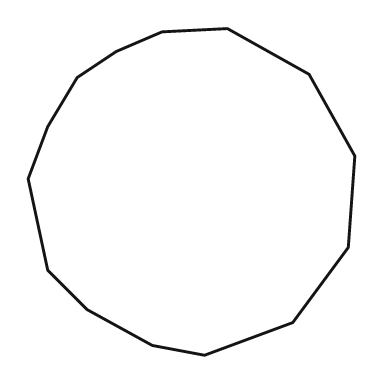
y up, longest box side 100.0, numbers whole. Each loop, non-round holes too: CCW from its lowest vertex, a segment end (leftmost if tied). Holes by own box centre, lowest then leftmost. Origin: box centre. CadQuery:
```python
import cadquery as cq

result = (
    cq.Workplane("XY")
    .moveTo(4.0, -50.0)
    .lineTo(31.0, -40.0)
    .lineTo(48.0, -17.0)
    .lineTo(50.0, 11.0)
    .lineTo(36.0, 36.0)
    .lineTo(11.0, 50.0)
    .lineTo(-9.0, 49.0)
    .lineTo(-23.0, 43.0)
    .lineTo(-35.0, 35.0)
    .lineTo(-44.0, 20.0)
    .lineTo(-50.0, 4.0)
    .lineTo(-44.0, -24.0)
    .lineTo(-32.0, -36.0)
    .lineTo(-12.0, -47.0)
    .close()
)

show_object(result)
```